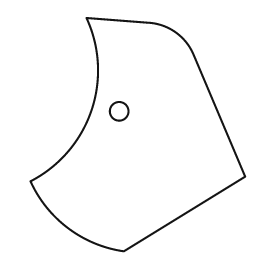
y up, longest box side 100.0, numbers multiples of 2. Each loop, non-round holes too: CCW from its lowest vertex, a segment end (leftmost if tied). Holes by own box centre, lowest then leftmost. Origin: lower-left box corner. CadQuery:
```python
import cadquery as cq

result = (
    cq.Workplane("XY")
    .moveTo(40.0, 0.0)
    .lineTo(92.0, 32.0)
    .lineTo(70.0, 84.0)
    .threePointArc((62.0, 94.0), (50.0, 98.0))
    .lineTo(24.0, 100.0)
    .threePointArc((26.0, 60.0), (0.0, 30.0))
    .threePointArc((16.0, 10.0), (40.0, 0.0))
    .close()
    .moveTo(38.0, 60.0)
    .circle(4.0)
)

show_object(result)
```